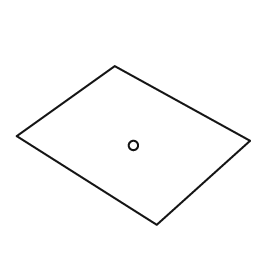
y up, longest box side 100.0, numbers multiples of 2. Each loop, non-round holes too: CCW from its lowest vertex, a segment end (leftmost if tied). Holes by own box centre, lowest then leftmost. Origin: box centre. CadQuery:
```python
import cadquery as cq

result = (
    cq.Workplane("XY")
    .moveTo(10.0, -34.0)
    .lineTo(50.0, 2.0)
    .lineTo(-8.0, 34.0)
    .lineTo(-50.0, 4.0)
    .close()
    .moveTo(0.0, 0.0)
    .circle(2.0)
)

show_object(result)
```